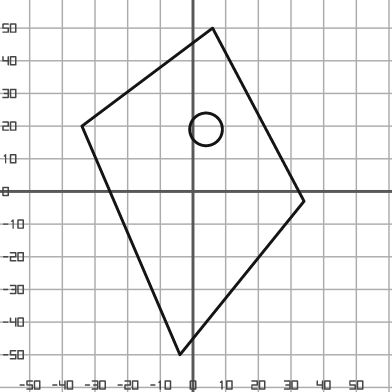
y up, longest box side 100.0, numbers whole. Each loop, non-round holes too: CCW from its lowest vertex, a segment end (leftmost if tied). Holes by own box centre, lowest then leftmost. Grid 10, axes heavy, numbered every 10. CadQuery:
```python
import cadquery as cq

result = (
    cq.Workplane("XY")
    .moveTo(-4.0, -50.0)
    .lineTo(34.0, -3.0)
    .lineTo(6.0, 50.0)
    .lineTo(-34.0, 20.0)
    .close()
    .moveTo(4.0, 19.0)
    .circle(5.0)
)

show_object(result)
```